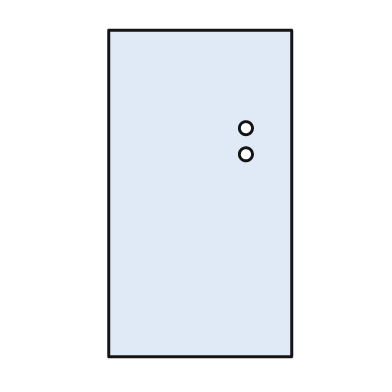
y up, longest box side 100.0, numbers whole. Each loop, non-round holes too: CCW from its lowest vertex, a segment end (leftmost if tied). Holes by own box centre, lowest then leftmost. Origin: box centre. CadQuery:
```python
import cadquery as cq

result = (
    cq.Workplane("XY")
    .moveTo(-28.0, -50.0)
    .lineTo(28.0, -50.0)
    .lineTo(28.0, 50.0)
    .lineTo(-28.0, 50.0)
    .close()
    .moveTo(14.0, 12.0)
    .circle(2.0)
    .moveTo(14.0, 20.0)
    .circle(2.0)
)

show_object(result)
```